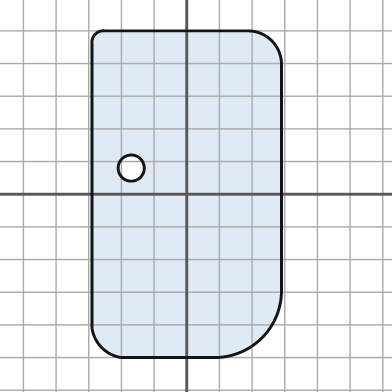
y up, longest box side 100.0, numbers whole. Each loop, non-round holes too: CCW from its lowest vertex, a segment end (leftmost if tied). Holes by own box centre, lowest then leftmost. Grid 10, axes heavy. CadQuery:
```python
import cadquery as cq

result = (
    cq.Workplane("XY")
    .moveTo(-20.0, -50.0)
    .lineTo(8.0, -50.0)
    .threePointArc((23.0, -44.0), (29.0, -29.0))
    .lineTo(29.0, 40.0)
    .threePointArc((26.0, 47.0), (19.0, 50.0))
    .lineTo(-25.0, 50.0)
    .threePointArc((-28.0, 49.0), (-29.0, 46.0))
    .lineTo(-29.0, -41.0)
    .threePointArc((-26.0, -47.0), (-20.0, -50.0))
    .close()
    .moveTo(-17.0, 8.0)
    .circle(4.0)
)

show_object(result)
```